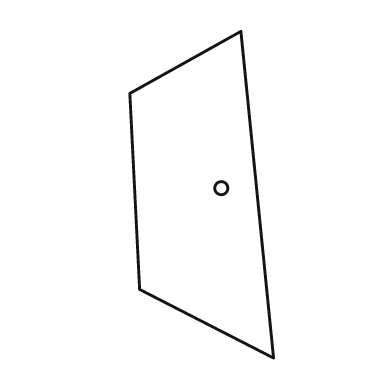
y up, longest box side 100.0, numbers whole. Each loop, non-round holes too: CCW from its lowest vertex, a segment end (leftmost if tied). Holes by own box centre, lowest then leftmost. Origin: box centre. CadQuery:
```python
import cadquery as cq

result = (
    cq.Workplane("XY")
    .moveTo(22.0, -50.0)
    .lineTo(12.0, 50.0)
    .lineTo(-22.0, 31.0)
    .lineTo(-19.0, -29.0)
    .close()
    .moveTo(6.0, 2.0)
    .circle(2.0)
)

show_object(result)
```